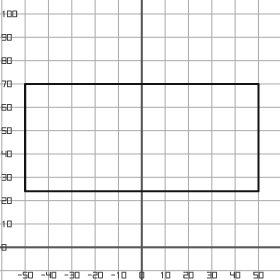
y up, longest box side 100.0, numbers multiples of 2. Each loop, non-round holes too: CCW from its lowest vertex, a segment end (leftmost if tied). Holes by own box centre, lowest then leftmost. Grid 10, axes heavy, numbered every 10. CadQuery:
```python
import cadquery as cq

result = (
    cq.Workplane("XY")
    .moveTo(-50.0, 24.0)
    .lineTo(50.0, 24.0)
    .lineTo(50.0, 70.0)
    .lineTo(-50.0, 70.0)
    .close()
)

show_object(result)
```